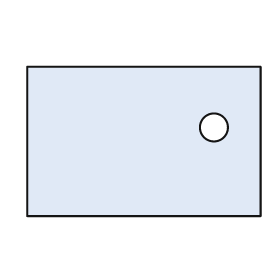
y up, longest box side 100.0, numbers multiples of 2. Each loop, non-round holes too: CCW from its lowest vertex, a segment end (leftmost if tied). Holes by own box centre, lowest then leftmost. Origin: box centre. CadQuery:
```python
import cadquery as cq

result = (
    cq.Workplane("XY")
    .moveTo(-50.0, -32.0)
    .lineTo(50.0, -32.0)
    .lineTo(50.0, 32.0)
    .lineTo(-50.0, 32.0)
    .close()
    .moveTo(30.0, 6.0)
    .circle(6.0)
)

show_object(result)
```